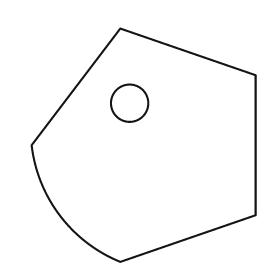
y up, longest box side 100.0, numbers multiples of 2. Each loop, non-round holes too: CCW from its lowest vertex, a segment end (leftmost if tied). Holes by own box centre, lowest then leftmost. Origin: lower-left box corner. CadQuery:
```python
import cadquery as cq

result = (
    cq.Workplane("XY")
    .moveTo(38.0, 0.0)
    .lineTo(96.0, 20.0)
    .lineTo(96.0, 80.0)
    .lineTo(38.0, 100.0)
    .lineTo(0.0, 50.0)
    .threePointArc((12.0, 20.0), (38.0, 0.0))
    .close()
    .moveTo(42.0, 68.0)
    .circle(8.0)
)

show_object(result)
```